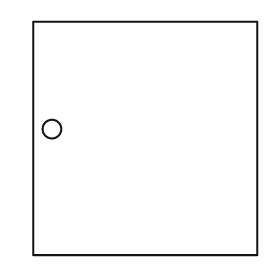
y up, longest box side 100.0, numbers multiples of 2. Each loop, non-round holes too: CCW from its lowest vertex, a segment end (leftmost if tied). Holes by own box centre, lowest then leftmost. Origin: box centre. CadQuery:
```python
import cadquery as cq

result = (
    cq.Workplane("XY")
    .moveTo(-48.0, -50.0)
    .lineTo(48.0, -50.0)
    .lineTo(48.0, 50.0)
    .lineTo(-48.0, 50.0)
    .close()
    .moveTo(-40.0, 4.0)
    .circle(4.0)
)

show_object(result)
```